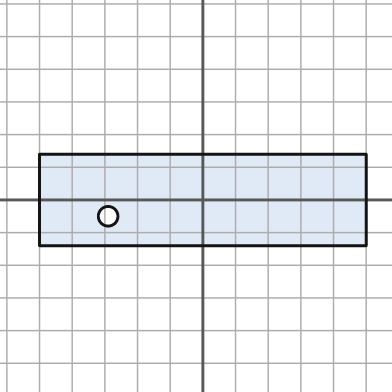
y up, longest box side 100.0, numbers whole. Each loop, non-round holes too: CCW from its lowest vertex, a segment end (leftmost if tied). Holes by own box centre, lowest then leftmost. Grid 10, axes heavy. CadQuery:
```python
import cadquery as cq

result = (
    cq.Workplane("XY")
    .moveTo(-50.0, -14.0)
    .lineTo(50.0, -14.0)
    .lineTo(50.0, 14.0)
    .lineTo(-50.0, 14.0)
    .close()
    .moveTo(-29.0, -5.0)
    .circle(3.0)
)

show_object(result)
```